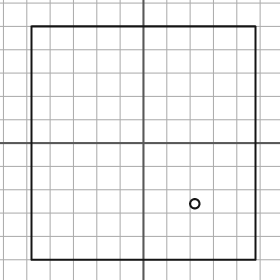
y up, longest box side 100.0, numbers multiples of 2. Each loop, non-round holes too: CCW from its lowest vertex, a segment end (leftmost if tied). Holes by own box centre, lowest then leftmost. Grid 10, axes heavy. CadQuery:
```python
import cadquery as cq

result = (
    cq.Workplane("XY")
    .moveTo(-48.0, -50.0)
    .lineTo(48.0, -50.0)
    .lineTo(48.0, 50.0)
    .lineTo(-48.0, 50.0)
    .close()
    .moveTo(22.0, -26.0)
    .circle(2.0)
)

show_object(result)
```